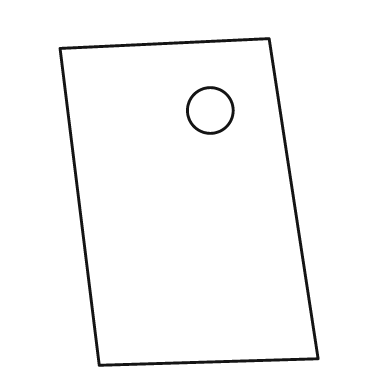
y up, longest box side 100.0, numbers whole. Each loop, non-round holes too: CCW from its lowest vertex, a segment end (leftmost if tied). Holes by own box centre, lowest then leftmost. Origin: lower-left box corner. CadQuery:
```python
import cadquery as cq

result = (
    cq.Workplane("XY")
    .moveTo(12.0, 0.0)
    .lineTo(79.0, 2.0)
    .lineTo(64.0, 100.0)
    .lineTo(0.0, 97.0)
    .close()
    .moveTo(46.0, 78.0)
    .circle(7.0)
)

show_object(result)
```